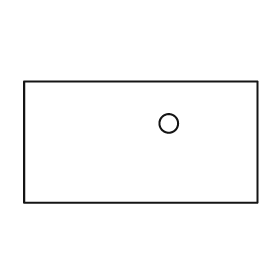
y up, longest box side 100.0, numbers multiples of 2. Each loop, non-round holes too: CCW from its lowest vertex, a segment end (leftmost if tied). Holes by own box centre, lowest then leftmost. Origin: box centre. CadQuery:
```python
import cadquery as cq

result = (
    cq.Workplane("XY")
    .moveTo(-50.0, -26.0)
    .lineTo(50.0, -26.0)
    .lineTo(50.0, 26.0)
    .lineTo(-50.0, 26.0)
    .close()
    .moveTo(12.0, 8.0)
    .circle(4.0)
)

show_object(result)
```